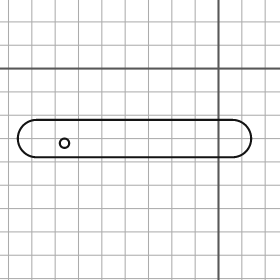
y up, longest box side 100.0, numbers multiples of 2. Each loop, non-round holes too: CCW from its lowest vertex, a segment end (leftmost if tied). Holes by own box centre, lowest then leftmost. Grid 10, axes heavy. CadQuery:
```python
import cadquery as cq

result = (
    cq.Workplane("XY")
    .moveTo(-78.0, -38.0)
    .lineTo(6.0, -38.0)
    .threePointArc((14.0, -30.0), (6.0, -22.0))
    .lineTo(-78.0, -22.0)
    .threePointArc((-86.0, -30.0), (-78.0, -38.0))
    .close()
    .moveTo(-66.0, -32.0)
    .circle(2.0)
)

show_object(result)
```